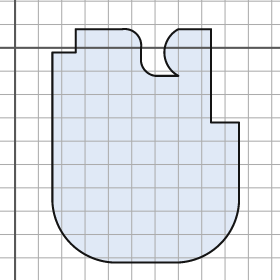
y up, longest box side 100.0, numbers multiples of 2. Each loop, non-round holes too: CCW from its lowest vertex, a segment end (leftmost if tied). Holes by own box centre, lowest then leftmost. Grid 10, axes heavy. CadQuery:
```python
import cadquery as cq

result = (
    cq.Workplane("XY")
    .moveTo(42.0, -92.0)
    .lineTo(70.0, -92.0)
    .threePointArc((88.0, -84.0), (96.0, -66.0))
    .lineTo(96.0, -32.0)
    .lineTo(84.0, -32.0)
    .lineTo(84.0, 8.0)
    .lineTo(70.0, 8.0)
    .threePointArc((64.0, -2.0), (70.0, -12.0))
    .lineTo(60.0, -12.0)
    .threePointArc((56.0, -10.0), (54.0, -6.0))
    .lineTo(54.0, 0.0)
    .threePointArc((52.0, 6.0), (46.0, 8.0))
    .lineTo(26.0, 8.0)
    .lineTo(26.0, -2.0)
    .lineTo(16.0, -2.0)
    .lineTo(16.0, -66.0)
    .threePointArc((24.0, -84.0), (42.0, -92.0))
    .close()
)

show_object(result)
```